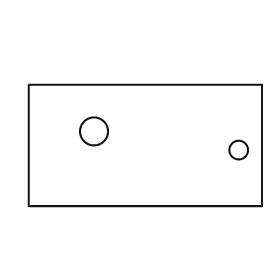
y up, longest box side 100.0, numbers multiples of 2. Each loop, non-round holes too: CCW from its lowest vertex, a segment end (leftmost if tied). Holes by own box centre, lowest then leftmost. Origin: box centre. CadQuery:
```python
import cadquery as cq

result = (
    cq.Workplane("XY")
    .moveTo(-50.0, -26.0)
    .lineTo(50.0, -26.0)
    .lineTo(50.0, 26.0)
    .lineTo(-50.0, 26.0)
    .close()
    .moveTo(40.0, -2.0)
    .circle(4.0)
    .moveTo(-22.0, 6.0)
    .circle(6.0)
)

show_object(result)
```